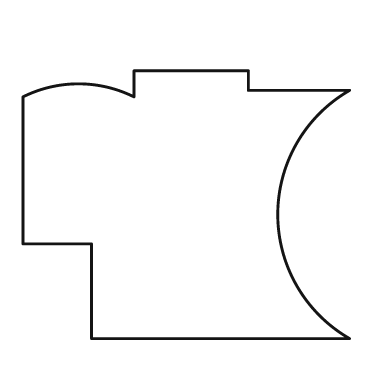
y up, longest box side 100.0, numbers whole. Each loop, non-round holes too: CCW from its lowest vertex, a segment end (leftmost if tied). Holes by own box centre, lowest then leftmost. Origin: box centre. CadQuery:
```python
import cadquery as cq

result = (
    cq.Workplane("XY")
    .moveTo(-29.0, -41.0)
    .lineTo(50.0, -41.0)
    .threePointArc((28.0, -3.0), (50.0, 35.0))
    .lineTo(19.0, 35.0)
    .lineTo(19.0, 41.0)
    .lineTo(-16.0, 41.0)
    .lineTo(-16.0, 33.0)
    .threePointArc((-33.0, 37.0), (-50.0, 33.0))
    .lineTo(-50.0, -12.0)
    .lineTo(-29.0, -12.0)
    .close()
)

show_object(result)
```